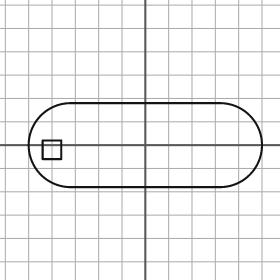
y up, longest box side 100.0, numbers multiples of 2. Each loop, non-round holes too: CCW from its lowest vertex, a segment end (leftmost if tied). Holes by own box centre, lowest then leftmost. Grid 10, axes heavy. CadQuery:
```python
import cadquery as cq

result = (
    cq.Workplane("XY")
    .moveTo(-32.0, -18.0)
    .lineTo(32.0, -18.0)
    .threePointArc((50.0, 0.0), (32.0, 18.0))
    .lineTo(-32.0, 18.0)
    .threePointArc((-50.0, 0.0), (-32.0, -18.0))
    .close()
    .moveTo(-44.0, -6.0)
    .lineTo(-36.0, -6.0)
    .lineTo(-36.0, 2.0)
    .lineTo(-44.0, 2.0)
    .close()
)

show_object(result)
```